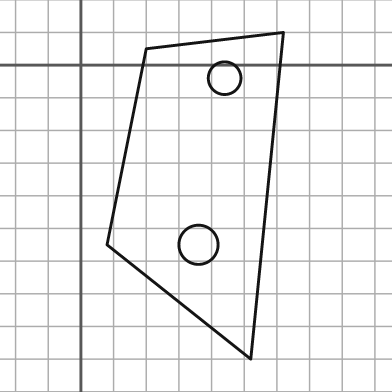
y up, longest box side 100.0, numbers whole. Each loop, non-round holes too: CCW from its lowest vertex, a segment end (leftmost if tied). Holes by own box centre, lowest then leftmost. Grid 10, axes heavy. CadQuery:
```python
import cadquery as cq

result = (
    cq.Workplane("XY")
    .moveTo(52.0, -90.0)
    .lineTo(62.0, 10.0)
    .lineTo(20.0, 5.0)
    .lineTo(8.0, -55.0)
    .close()
    .moveTo(36.0, -55.0)
    .circle(6.0)
    .moveTo(44.0, -4.0)
    .circle(5.0)
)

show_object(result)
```